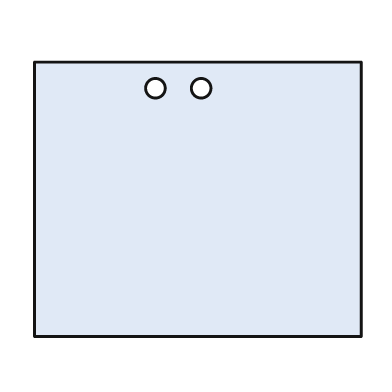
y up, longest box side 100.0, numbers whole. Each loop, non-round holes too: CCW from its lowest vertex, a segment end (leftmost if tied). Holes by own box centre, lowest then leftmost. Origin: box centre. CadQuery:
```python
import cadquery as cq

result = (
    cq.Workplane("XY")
    .moveTo(-50.0, -42.0)
    .lineTo(50.0, -42.0)
    .lineTo(50.0, 42.0)
    .lineTo(-50.0, 42.0)
    .close()
    .moveTo(-13.0, 34.0)
    .circle(3.0)
    .moveTo(1.0, 34.0)
    .circle(3.0)
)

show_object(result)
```